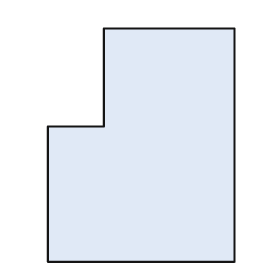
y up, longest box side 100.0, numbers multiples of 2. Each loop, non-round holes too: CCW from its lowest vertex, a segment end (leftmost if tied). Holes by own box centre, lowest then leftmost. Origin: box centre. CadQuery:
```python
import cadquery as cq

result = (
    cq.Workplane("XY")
    .moveTo(-40.0, -50.0)
    .lineTo(40.0, -50.0)
    .lineTo(40.0, 50.0)
    .lineTo(-16.0, 50.0)
    .lineTo(-16.0, 8.0)
    .lineTo(-40.0, 8.0)
    .close()
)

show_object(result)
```